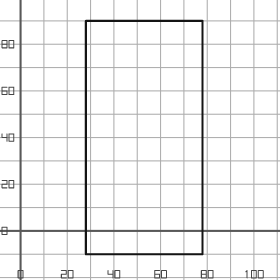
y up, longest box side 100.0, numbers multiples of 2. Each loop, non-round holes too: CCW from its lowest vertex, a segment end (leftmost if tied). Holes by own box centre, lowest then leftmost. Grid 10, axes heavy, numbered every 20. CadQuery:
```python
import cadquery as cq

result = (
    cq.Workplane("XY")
    .moveTo(28.0, -10.0)
    .lineTo(78.0, -10.0)
    .lineTo(78.0, 90.0)
    .lineTo(28.0, 90.0)
    .close()
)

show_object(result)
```